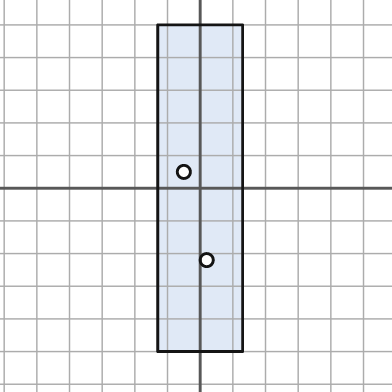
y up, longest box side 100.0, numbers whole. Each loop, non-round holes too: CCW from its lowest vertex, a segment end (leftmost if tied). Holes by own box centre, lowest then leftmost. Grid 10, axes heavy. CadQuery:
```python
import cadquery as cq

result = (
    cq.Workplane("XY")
    .moveTo(-13.0, -50.0)
    .lineTo(13.0, -50.0)
    .lineTo(13.0, 50.0)
    .lineTo(-13.0, 50.0)
    .close()
    .moveTo(2.0, -22.0)
    .circle(2.0)
    .moveTo(-5.0, 5.0)
    .circle(2.0)
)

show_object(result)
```